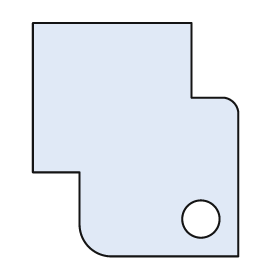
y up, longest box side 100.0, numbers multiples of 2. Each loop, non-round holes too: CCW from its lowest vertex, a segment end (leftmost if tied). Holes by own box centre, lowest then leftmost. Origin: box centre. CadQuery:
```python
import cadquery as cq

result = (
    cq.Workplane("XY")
    .moveTo(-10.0, -50.0)
    .lineTo(44.0, -50.0)
    .lineTo(44.0, 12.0)
    .threePointArc((42.0, 16.0), (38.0, 18.0))
    .lineTo(24.0, 18.0)
    .lineTo(24.0, 50.0)
    .lineTo(-44.0, 50.0)
    .lineTo(-44.0, -14.0)
    .lineTo(-24.0, -14.0)
    .lineTo(-24.0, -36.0)
    .threePointArc((-20.0, -46.0), (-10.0, -50.0))
    .close()
    .moveTo(28.0, -34.0)
    .circle(8.0)
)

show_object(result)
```